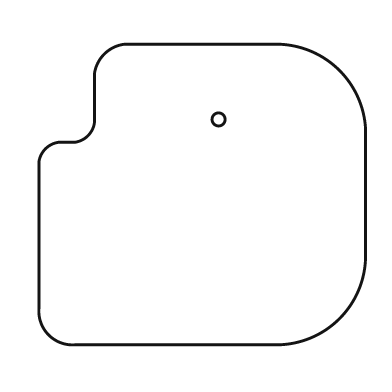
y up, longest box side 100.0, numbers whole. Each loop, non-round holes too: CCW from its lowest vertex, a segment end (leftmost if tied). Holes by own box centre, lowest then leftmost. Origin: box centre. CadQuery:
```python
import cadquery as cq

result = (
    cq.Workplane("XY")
    .moveTo(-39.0, -46.0)
    .lineTo(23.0, -46.0)
    .threePointArc((42.0, -38.0), (50.0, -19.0))
    .lineTo(50.0, 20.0)
    .threePointArc((42.0, 38.0), (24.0, 46.0))
    .lineTo(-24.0, 46.0)
    .threePointArc((-30.0, 43.0), (-33.0, 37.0))
    .lineTo(-33.0, 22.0)
    .threePointArc((-35.0, 18.0), (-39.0, 16.0))
    .lineTo(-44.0, 16.0)
    .threePointArc((-48.0, 14.0), (-50.0, 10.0))
    .lineTo(-50.0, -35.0)
    .threePointArc((-47.0, -43.0), (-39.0, -46.0))
    .close()
    .moveTo(5.0, 23.0)
    .circle(2.0)
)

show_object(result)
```